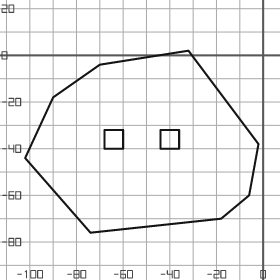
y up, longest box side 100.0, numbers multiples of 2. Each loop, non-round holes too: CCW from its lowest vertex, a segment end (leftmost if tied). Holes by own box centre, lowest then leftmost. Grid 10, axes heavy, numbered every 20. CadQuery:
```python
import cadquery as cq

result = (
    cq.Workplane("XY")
    .moveTo(-74.0, -76.0)
    .lineTo(-18.0, -70.0)
    .lineTo(-6.0, -60.0)
    .lineTo(-2.0, -38.0)
    .lineTo(-32.0, 2.0)
    .lineTo(-70.0, -4.0)
    .lineTo(-90.0, -18.0)
    .lineTo(-102.0, -44.0)
    .close()
    .moveTo(-68.0, -40.0)
    .lineTo(-60.0, -40.0)
    .lineTo(-60.0, -32.0)
    .lineTo(-68.0, -32.0)
    .close()
    .moveTo(-44.0, -40.0)
    .lineTo(-36.0, -40.0)
    .lineTo(-36.0, -32.0)
    .lineTo(-44.0, -32.0)
    .close()
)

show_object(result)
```